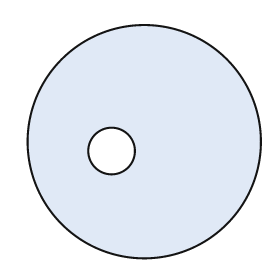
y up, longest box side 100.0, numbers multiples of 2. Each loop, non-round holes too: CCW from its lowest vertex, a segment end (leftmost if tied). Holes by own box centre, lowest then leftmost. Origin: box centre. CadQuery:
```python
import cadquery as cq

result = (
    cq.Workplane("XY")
    .moveTo(0.0, 0.0)
    .circle(50.0)
    .moveTo(-14.0, -4.0)
    .circle(10.0)
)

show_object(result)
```